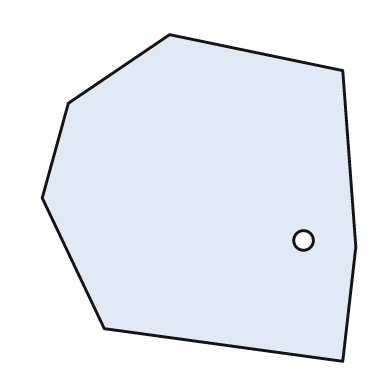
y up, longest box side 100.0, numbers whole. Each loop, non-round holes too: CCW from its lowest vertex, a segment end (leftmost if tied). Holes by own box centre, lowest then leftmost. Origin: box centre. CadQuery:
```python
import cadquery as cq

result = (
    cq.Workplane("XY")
    .moveTo(44.0, -50.0)
    .lineTo(48.0, -15.0)
    .lineTo(44.0, 39.0)
    .lineTo(-9.0, 50.0)
    .lineTo(-40.0, 29.0)
    .lineTo(-48.0, 0.0)
    .lineTo(-29.0, -40.0)
    .close()
    .moveTo(32.0, -13.0)
    .circle(3.0)
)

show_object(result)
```